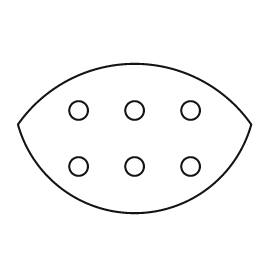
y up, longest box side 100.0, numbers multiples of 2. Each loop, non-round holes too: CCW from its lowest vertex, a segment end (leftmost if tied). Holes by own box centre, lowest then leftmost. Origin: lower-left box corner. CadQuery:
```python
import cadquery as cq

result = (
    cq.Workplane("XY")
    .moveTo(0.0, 38.0)
    .threePointArc((50.0, 0.0), (100.0, 38.0))
    .threePointArc((50.0, 64.0), (0.0, 38.0))
    .close()
    .moveTo(26.0, 20.0)
    .circle(4.0)
    .moveTo(50.0, 20.0)
    .circle(4.0)
    .moveTo(74.0, 20.0)
    .circle(4.0)
    .moveTo(26.0, 44.0)
    .circle(4.0)
    .moveTo(50.0, 44.0)
    .circle(4.0)
    .moveTo(74.0, 44.0)
    .circle(4.0)
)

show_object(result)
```